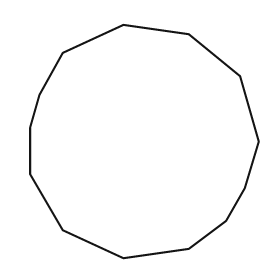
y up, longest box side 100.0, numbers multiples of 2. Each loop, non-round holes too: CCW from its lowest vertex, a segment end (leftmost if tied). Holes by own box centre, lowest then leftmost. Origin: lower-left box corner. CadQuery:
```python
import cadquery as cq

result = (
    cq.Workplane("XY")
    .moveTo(40.0, 0.0)
    .lineTo(68.0, 4.0)
    .lineTo(84.0, 16.0)
    .lineTo(92.0, 30.0)
    .lineTo(98.0, 50.0)
    .lineTo(90.0, 78.0)
    .lineTo(68.0, 96.0)
    .lineTo(40.0, 100.0)
    .lineTo(14.0, 88.0)
    .lineTo(4.0, 70.0)
    .lineTo(0.0, 56.0)
    .lineTo(0.0, 36.0)
    .lineTo(14.0, 12.0)
    .close()
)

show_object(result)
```